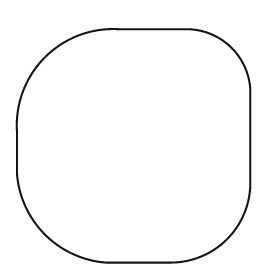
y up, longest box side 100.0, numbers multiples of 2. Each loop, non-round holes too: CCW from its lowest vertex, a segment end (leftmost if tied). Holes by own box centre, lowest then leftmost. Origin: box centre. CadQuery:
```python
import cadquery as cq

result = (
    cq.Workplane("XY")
    .moveTo(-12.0, -50.0)
    .lineTo(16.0, -50.0)
    .threePointArc((40.0, -40.0), (50.0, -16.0))
    .lineTo(50.0, 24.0)
    .threePointArc((42.0, 42.0), (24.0, 50.0))
    .lineTo(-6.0, 50.0)
    .threePointArc((-38.0, 38.0), (-50.0, 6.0))
    .lineTo(-50.0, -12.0)
    .threePointArc((-38.0, -38.0), (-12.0, -50.0))
    .close()
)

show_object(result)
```